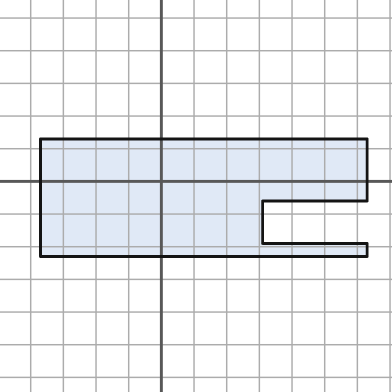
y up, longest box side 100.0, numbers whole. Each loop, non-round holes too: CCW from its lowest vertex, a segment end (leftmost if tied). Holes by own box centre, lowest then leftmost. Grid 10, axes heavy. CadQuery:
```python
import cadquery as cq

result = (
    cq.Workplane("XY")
    .moveTo(-37.0, -23.0)
    .lineTo(63.0, -23.0)
    .lineTo(63.0, -19.0)
    .lineTo(31.0, -19.0)
    .lineTo(31.0, -6.0)
    .lineTo(63.0, -6.0)
    .lineTo(63.0, 13.0)
    .lineTo(-37.0, 13.0)
    .close()
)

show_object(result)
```